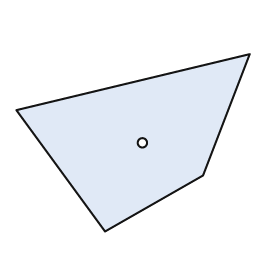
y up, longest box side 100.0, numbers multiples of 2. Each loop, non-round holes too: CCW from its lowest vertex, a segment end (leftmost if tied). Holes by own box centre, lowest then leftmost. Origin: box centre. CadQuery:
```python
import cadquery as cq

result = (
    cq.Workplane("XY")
    .moveTo(-12.0, -38.0)
    .lineTo(30.0, -14.0)
    .lineTo(50.0, 38.0)
    .lineTo(-50.0, 14.0)
    .close()
    .moveTo(4.0, 0.0)
    .circle(2.0)
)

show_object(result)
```